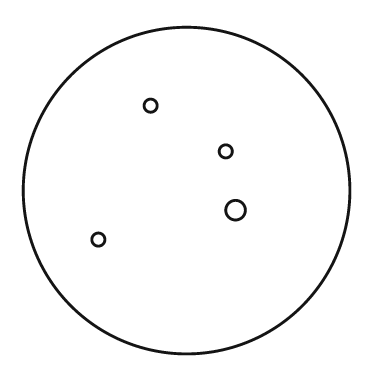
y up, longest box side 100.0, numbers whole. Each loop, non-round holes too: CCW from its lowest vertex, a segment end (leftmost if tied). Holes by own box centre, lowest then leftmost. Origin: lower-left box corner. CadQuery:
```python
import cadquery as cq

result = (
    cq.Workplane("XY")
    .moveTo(50.0, 50.0)
    .circle(50.0)
    .moveTo(23.0, 35.0)
    .circle(2.0)
    .moveTo(65.0, 44.0)
    .circle(3.0)
    .moveTo(62.0, 62.0)
    .circle(2.0)
    .moveTo(39.0, 76.0)
    .circle(2.0)
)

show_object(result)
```